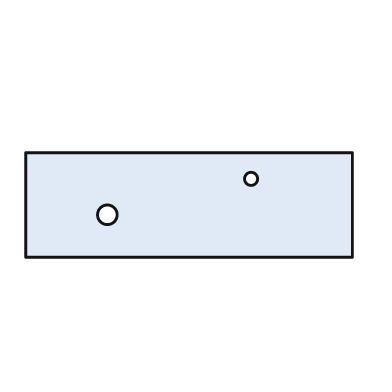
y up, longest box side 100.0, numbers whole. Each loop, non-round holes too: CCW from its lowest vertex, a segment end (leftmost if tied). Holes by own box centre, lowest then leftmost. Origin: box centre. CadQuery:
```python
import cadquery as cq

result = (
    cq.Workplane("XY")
    .moveTo(-50.0, -16.0)
    .lineTo(50.0, -16.0)
    .lineTo(50.0, 16.0)
    .lineTo(-50.0, 16.0)
    .close()
    .moveTo(-25.0, -3.0)
    .circle(3.0)
    .moveTo(19.0, 8.0)
    .circle(2.0)
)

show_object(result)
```